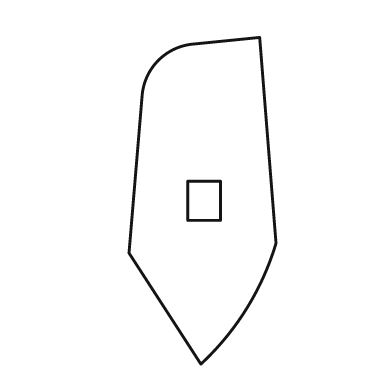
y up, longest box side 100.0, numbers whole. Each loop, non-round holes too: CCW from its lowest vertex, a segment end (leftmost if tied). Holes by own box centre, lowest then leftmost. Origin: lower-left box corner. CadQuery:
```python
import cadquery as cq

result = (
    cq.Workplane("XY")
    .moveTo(22.0, 0.0)
    .threePointArc((36.0, 17.0), (45.0, 37.0))
    .lineTo(40.0, 100.0)
    .lineTo(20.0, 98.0)
    .threePointArc((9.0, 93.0), (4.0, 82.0))
    .lineTo(0.0, 34.0)
    .close()
    .moveTo(18.0, 44.0)
    .lineTo(28.0, 44.0)
    .lineTo(28.0, 56.0)
    .lineTo(18.0, 56.0)
    .close()
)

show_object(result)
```